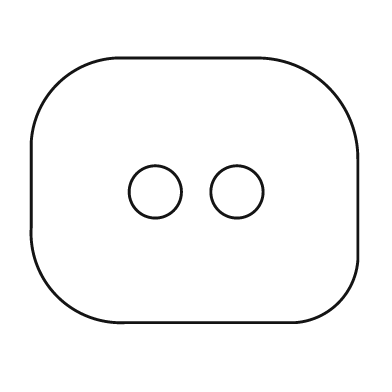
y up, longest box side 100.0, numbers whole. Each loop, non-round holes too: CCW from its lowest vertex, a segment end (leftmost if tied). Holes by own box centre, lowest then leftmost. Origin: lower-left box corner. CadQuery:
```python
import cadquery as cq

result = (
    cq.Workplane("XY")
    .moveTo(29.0, 0.0)
    .lineTo(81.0, 0.0)
    .threePointArc((94.0, 6.0), (100.0, 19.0))
    .lineTo(100.0, 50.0)
    .threePointArc((91.0, 72.0), (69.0, 81.0))
    .lineTo(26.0, 81.0)
    .threePointArc((8.0, 73.0), (0.0, 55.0))
    .lineTo(0.0, 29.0)
    .threePointArc((8.0, 8.0), (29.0, 0.0))
    .close()
    .moveTo(38.0, 40.0)
    .circle(8.0)
    .moveTo(63.0, 40.0)
    .circle(8.0)
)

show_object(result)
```